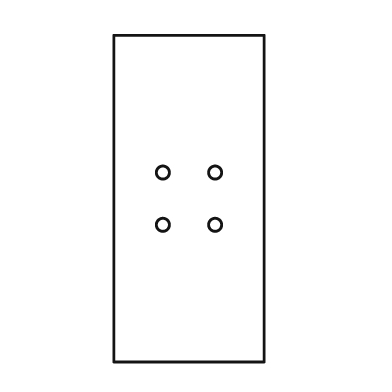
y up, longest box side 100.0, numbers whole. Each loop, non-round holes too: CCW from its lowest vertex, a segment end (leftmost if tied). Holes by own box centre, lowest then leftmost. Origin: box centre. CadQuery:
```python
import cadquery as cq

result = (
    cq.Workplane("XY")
    .moveTo(-23.0, -50.0)
    .lineTo(23.0, -50.0)
    .lineTo(23.0, 50.0)
    .lineTo(-23.0, 50.0)
    .close()
    .moveTo(-8.0, -8.0)
    .circle(2.0)
    .moveTo(8.0, -8.0)
    .circle(2.0)
    .moveTo(-8.0, 8.0)
    .circle(2.0)
    .moveTo(8.0, 8.0)
    .circle(2.0)
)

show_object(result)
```